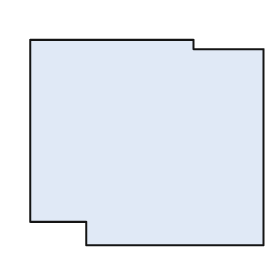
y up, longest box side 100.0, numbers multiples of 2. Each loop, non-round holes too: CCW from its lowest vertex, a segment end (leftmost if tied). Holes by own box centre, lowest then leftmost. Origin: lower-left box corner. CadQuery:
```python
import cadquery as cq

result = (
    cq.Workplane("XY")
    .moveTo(24.0, 0.0)
    .lineTo(100.0, 0.0)
    .lineTo(100.0, 84.0)
    .lineTo(70.0, 84.0)
    .lineTo(70.0, 88.0)
    .lineTo(0.0, 88.0)
    .lineTo(0.0, 10.0)
    .lineTo(24.0, 10.0)
    .close()
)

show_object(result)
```